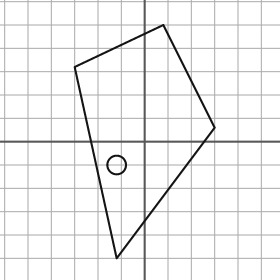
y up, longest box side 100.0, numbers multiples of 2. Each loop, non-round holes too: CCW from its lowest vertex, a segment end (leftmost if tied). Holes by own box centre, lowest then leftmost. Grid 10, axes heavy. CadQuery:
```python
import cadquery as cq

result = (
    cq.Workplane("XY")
    .moveTo(-12.0, -50.0)
    .lineTo(30.0, 6.0)
    .lineTo(8.0, 50.0)
    .lineTo(-30.0, 32.0)
    .close()
    .moveTo(-12.0, -10.0)
    .circle(4.0)
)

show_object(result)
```